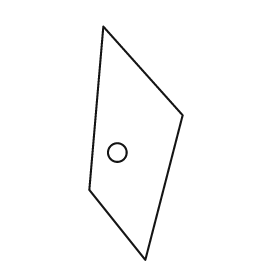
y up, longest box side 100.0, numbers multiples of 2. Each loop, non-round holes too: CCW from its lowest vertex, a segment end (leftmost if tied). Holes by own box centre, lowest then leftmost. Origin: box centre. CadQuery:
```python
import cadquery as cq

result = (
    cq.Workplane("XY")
    .moveTo(4.0, -50.0)
    .lineTo(20.0, 12.0)
    .lineTo(-14.0, 50.0)
    .lineTo(-20.0, -20.0)
    .close()
    .moveTo(-8.0, -4.0)
    .circle(4.0)
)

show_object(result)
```